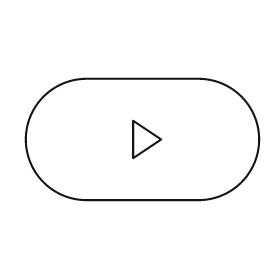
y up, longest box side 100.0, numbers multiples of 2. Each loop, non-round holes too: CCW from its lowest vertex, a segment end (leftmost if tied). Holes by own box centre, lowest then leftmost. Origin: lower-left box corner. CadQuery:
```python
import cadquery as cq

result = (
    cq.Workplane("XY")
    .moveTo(26.0, 0.0)
    .lineTo(74.0, 0.0)
    .threePointArc((100.0, 26.0), (74.0, 52.0))
    .lineTo(26.0, 52.0)
    .threePointArc((0.0, 26.0), (26.0, 0.0))
    .close()
    .moveTo(46.0, 18.0)
    .lineTo(58.0, 26.0)
    .lineTo(46.0, 34.0)
    .close()
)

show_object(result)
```